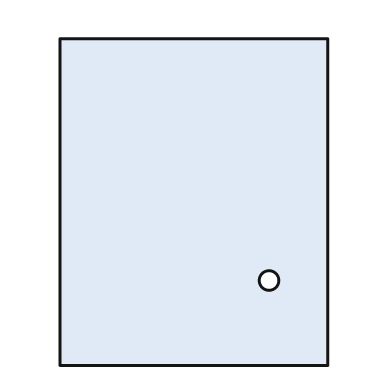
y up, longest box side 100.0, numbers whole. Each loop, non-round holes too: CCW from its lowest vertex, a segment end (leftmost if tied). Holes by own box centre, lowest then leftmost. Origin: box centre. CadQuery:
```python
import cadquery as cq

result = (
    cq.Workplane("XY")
    .moveTo(-41.0, -50.0)
    .lineTo(41.0, -50.0)
    .lineTo(41.0, 50.0)
    .lineTo(-41.0, 50.0)
    .close()
    .moveTo(23.0, -24.0)
    .circle(3.0)
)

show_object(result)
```